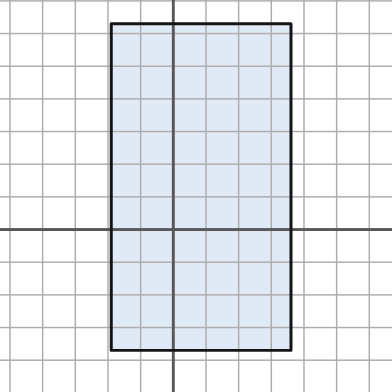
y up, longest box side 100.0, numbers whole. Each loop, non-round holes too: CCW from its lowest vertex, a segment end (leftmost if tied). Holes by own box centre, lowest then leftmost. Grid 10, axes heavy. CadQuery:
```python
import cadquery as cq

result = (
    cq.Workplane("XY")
    .moveTo(-19.0, -37.0)
    .lineTo(36.0, -37.0)
    .lineTo(36.0, 63.0)
    .lineTo(-19.0, 63.0)
    .close()
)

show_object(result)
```